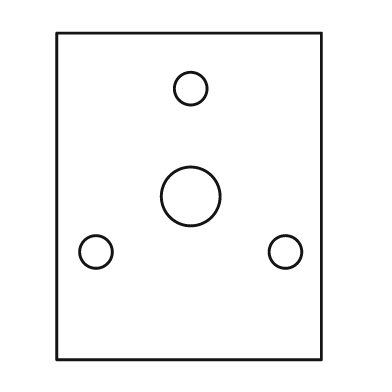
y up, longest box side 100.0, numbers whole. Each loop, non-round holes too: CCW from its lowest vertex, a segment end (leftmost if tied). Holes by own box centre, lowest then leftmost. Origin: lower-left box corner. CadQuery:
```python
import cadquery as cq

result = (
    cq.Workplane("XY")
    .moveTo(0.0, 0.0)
    .lineTo(81.0, 0.0)
    .lineTo(81.0, 100.0)
    .lineTo(0.0, 100.0)
    .close()
    .moveTo(12.0, 33.0)
    .circle(5.0)
    .moveTo(70.0, 33.0)
    .circle(5.0)
    .moveTo(41.0, 50.0)
    .circle(9.0)
    .moveTo(41.0, 83.0)
    .circle(5.0)
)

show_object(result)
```